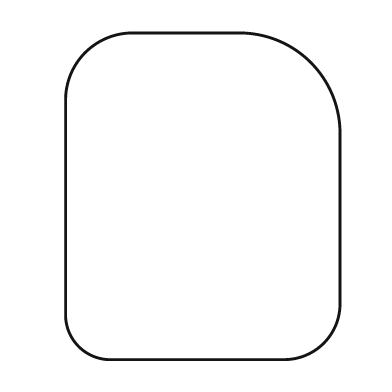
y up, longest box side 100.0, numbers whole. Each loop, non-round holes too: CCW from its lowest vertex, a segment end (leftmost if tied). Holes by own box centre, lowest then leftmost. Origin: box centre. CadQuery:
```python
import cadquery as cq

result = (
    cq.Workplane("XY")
    .moveTo(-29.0, -50.0)
    .lineTo(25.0, -50.0)
    .threePointArc((37.0, -45.0), (42.0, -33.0))
    .lineTo(42.0, 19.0)
    .threePointArc((33.0, 41.0), (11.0, 50.0))
    .lineTo(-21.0, 50.0)
    .threePointArc((-36.0, 44.0), (-42.0, 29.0))
    .lineTo(-42.0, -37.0)
    .threePointArc((-38.0, -46.0), (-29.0, -50.0))
    .close()
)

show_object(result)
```